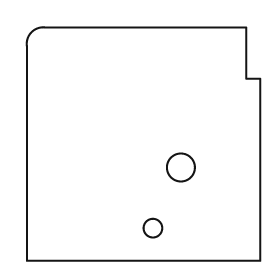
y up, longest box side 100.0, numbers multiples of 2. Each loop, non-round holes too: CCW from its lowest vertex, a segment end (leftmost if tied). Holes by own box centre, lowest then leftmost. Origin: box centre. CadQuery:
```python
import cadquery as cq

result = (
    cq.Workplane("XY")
    .moveTo(-50.0, -50.0)
    .lineTo(50.0, -50.0)
    .lineTo(50.0, 28.0)
    .lineTo(44.0, 28.0)
    .lineTo(44.0, 50.0)
    .lineTo(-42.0, 50.0)
    .threePointArc((-48.0, 48.0), (-50.0, 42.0))
    .close()
    .moveTo(4.0, -36.0)
    .circle(4.0)
    .moveTo(16.0, -10.0)
    .circle(6.0)
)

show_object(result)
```